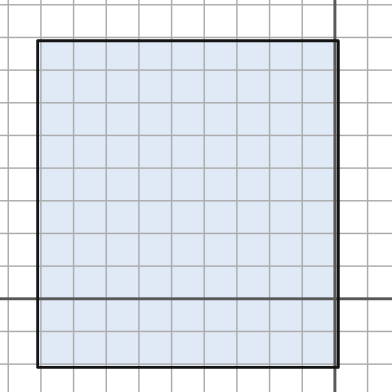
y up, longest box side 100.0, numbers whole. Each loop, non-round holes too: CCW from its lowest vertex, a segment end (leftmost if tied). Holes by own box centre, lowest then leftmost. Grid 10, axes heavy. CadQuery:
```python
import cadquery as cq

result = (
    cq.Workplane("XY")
    .moveTo(-91.0, -21.0)
    .lineTo(1.0, -21.0)
    .lineTo(1.0, 79.0)
    .lineTo(-91.0, 79.0)
    .close()
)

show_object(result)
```